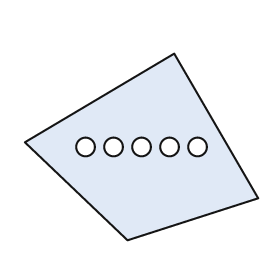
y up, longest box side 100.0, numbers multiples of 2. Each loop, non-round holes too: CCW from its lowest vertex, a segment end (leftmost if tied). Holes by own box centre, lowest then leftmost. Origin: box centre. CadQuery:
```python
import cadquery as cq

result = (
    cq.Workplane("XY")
    .moveTo(-6.0, -40.0)
    .lineTo(50.0, -22.0)
    .lineTo(14.0, 40.0)
    .lineTo(-50.0, 2.0)
    .close()
    .moveTo(-24.0, 0.0)
    .circle(4.0)
    .moveTo(-12.0, 0.0)
    .circle(4.0)
    .moveTo(0.0, 0.0)
    .circle(4.0)
    .moveTo(12.0, 0.0)
    .circle(4.0)
    .moveTo(24.0, 0.0)
    .circle(4.0)
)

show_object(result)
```